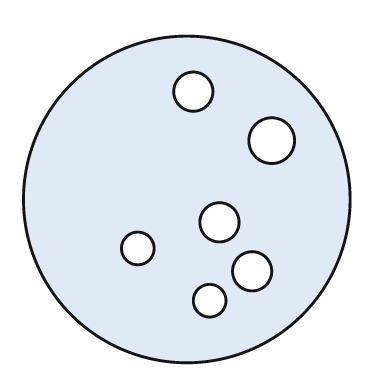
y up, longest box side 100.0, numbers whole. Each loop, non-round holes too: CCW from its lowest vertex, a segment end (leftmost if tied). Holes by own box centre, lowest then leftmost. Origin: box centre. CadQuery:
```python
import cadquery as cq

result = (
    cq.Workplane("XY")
    .moveTo(0.0, 0.0)
    .circle(50.0)
    .moveTo(7.0, -31.0)
    .circle(5.0)
    .moveTo(20.0, -22.0)
    .circle(6.0)
    .moveTo(-15.0, -15.0)
    .circle(5.0)
    .moveTo(10.0, -7.0)
    .circle(6.0)
    .moveTo(26.0, 18.0)
    .circle(7.0)
    .moveTo(2.0, 33.0)
    .circle(6.0)
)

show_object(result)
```